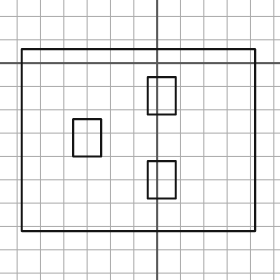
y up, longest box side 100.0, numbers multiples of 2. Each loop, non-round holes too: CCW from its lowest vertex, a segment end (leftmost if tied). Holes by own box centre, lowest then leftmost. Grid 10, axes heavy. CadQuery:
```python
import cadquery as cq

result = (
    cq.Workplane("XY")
    .moveTo(-58.0, -72.0)
    .lineTo(42.0, -72.0)
    .lineTo(42.0, 6.0)
    .lineTo(-58.0, 6.0)
    .close()
    .moveTo(-4.0, -58.0)
    .lineTo(8.0, -58.0)
    .lineTo(8.0, -42.0)
    .lineTo(-4.0, -42.0)
    .close()
    .moveTo(-36.0, -40.0)
    .lineTo(-24.0, -40.0)
    .lineTo(-24.0, -24.0)
    .lineTo(-36.0, -24.0)
    .close()
    .moveTo(-4.0, -22.0)
    .lineTo(8.0, -22.0)
    .lineTo(8.0, -6.0)
    .lineTo(-4.0, -6.0)
    .close()
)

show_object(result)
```